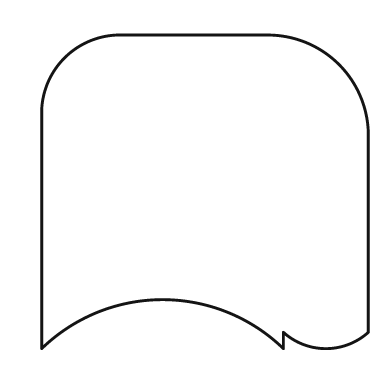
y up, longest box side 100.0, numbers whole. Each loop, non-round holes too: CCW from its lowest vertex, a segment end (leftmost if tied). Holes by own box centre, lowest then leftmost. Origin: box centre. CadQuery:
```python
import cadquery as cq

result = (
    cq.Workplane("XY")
    .moveTo(-50.0, -48.0)
    .threePointArc((-13.0, -33.0), (24.0, -48.0))
    .lineTo(24.0, -43.0)
    .threePointArc((37.0, -48.0), (50.0, -43.0))
    .lineTo(50.0, 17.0)
    .threePointArc((41.0, 39.0), (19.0, 48.0))
    .lineTo(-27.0, 48.0)
    .threePointArc((-43.0, 41.0), (-50.0, 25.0))
    .close()
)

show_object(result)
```